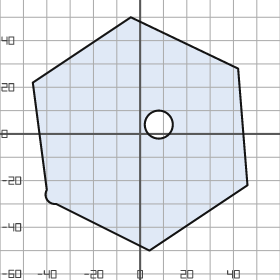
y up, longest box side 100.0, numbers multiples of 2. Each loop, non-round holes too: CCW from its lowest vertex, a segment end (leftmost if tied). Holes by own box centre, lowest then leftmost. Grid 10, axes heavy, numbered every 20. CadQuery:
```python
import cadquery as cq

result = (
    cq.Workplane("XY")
    .moveTo(4.0, -50.0)
    .lineTo(46.0, -22.0)
    .lineTo(42.0, 28.0)
    .lineTo(-4.0, 50.0)
    .lineTo(-46.0, 22.0)
    .lineTo(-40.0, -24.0)
    .threePointArc((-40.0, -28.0), (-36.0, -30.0))
    .close()
    .moveTo(8.0, 4.0)
    .circle(6.0)
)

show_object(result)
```